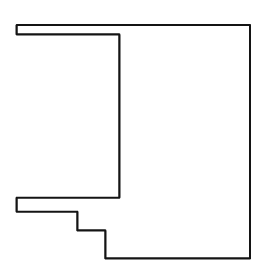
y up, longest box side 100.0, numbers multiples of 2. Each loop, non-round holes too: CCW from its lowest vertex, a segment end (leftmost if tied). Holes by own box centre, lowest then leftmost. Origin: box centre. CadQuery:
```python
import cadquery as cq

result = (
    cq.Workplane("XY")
    .moveTo(-12.0, -50.0)
    .lineTo(50.0, -50.0)
    .lineTo(50.0, 50.0)
    .lineTo(-50.0, 50.0)
    .lineTo(-50.0, 46.0)
    .lineTo(-6.0, 46.0)
    .lineTo(-6.0, -24.0)
    .lineTo(-50.0, -24.0)
    .lineTo(-50.0, -30.0)
    .lineTo(-24.0, -30.0)
    .lineTo(-24.0, -38.0)
    .lineTo(-12.0, -38.0)
    .close()
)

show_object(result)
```